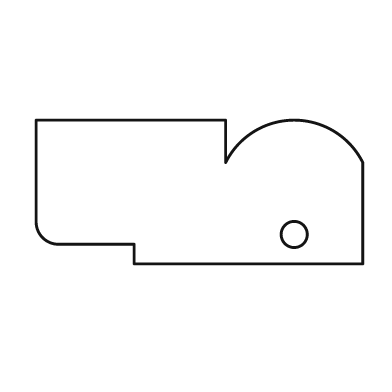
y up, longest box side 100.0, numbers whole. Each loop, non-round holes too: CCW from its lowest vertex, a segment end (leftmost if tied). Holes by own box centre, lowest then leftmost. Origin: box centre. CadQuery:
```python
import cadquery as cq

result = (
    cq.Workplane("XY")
    .moveTo(-20.0, -22.0)
    .lineTo(50.0, -22.0)
    .lineTo(50.0, 9.0)
    .threePointArc((29.0, 22.0), (8.0, 9.0))
    .lineTo(8.0, 22.0)
    .lineTo(-50.0, 22.0)
    .lineTo(-50.0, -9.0)
    .threePointArc((-48.0, -14.0), (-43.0, -16.0))
    .lineTo(-20.0, -16.0)
    .close()
    .moveTo(29.0, -13.0)
    .circle(4.0)
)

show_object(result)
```